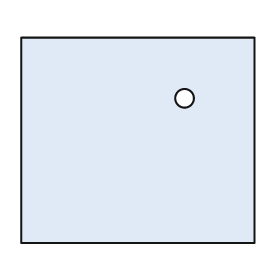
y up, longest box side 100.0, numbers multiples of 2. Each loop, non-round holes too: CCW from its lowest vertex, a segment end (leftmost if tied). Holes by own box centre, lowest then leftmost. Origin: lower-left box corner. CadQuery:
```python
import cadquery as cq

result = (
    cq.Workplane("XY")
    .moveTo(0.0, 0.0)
    .lineTo(100.0, 0.0)
    .lineTo(100.0, 88.0)
    .lineTo(0.0, 88.0)
    .close()
    .moveTo(70.0, 62.0)
    .circle(4.0)
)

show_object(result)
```